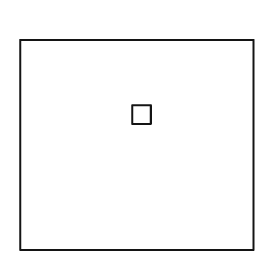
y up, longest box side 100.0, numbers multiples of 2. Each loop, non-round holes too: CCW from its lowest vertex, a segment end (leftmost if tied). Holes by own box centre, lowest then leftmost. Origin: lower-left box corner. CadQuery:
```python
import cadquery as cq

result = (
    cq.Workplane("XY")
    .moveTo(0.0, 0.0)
    .lineTo(100.0, 0.0)
    .lineTo(100.0, 90.0)
    .lineTo(0.0, 90.0)
    .close()
    .moveTo(48.0, 54.0)
    .lineTo(56.0, 54.0)
    .lineTo(56.0, 62.0)
    .lineTo(48.0, 62.0)
    .close()
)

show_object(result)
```